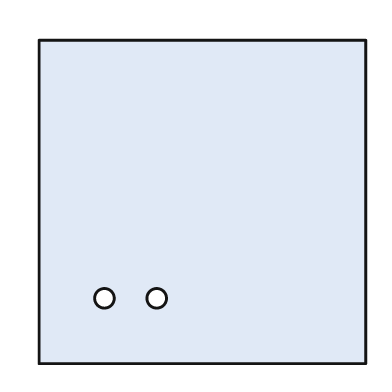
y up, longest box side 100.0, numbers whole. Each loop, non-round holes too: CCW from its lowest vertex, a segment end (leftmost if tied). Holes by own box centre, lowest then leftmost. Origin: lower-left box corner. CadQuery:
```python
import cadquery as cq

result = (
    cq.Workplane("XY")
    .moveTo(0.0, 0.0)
    .lineTo(100.0, 0.0)
    .lineTo(100.0, 99.0)
    .lineTo(0.0, 99.0)
    .close()
    .moveTo(20.0, 20.0)
    .circle(3.0)
    .moveTo(36.0, 20.0)
    .circle(3.0)
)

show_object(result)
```